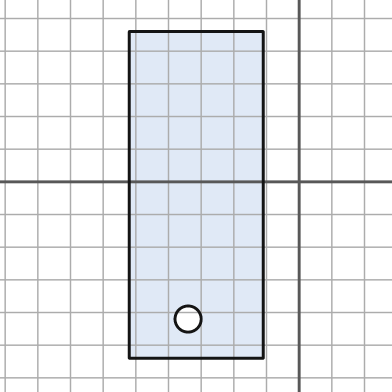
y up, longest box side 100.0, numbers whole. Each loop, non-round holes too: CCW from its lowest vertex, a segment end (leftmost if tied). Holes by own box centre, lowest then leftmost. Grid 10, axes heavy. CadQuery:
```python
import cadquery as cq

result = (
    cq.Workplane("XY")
    .moveTo(-52.0, -54.0)
    .lineTo(-11.0, -54.0)
    .lineTo(-11.0, 46.0)
    .lineTo(-52.0, 46.0)
    .close()
    .moveTo(-34.0, -42.0)
    .circle(4.0)
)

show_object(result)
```